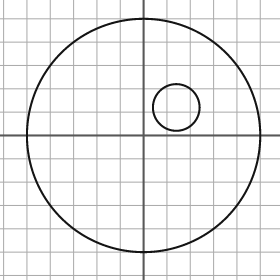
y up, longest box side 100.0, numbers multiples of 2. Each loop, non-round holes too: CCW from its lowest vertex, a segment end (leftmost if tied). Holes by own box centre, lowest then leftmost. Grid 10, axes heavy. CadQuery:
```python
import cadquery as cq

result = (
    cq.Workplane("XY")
    .moveTo(0.0, 0.0)
    .circle(50.0)
    .moveTo(14.0, 12.0)
    .circle(10.0)
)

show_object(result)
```